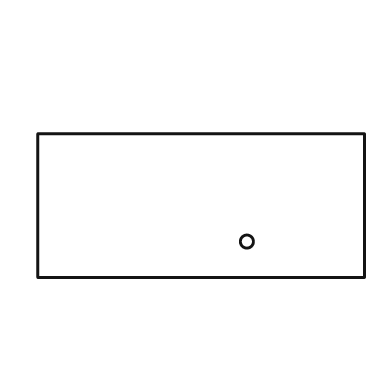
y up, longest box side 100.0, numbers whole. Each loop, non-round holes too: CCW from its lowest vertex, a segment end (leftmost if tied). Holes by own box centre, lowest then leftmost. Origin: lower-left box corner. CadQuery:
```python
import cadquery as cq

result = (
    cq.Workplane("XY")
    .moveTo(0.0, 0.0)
    .lineTo(100.0, 0.0)
    .lineTo(100.0, 44.0)
    .lineTo(0.0, 44.0)
    .close()
    .moveTo(64.0, 11.0)
    .circle(2.0)
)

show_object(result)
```